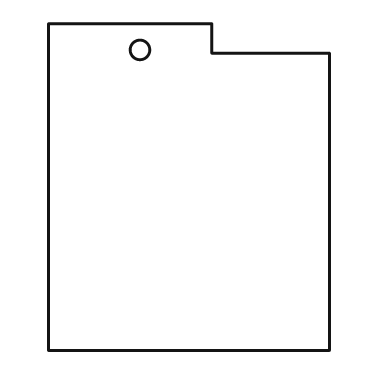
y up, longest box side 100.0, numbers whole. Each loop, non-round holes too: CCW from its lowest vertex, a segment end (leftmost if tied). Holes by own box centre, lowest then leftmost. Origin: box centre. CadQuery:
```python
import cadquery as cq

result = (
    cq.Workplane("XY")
    .moveTo(-43.0, -50.0)
    .lineTo(43.0, -50.0)
    .lineTo(43.0, 41.0)
    .lineTo(7.0, 41.0)
    .lineTo(7.0, 50.0)
    .lineTo(-43.0, 50.0)
    .close()
    .moveTo(-15.0, 42.0)
    .circle(3.0)
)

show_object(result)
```